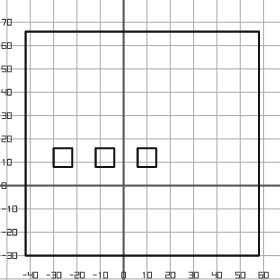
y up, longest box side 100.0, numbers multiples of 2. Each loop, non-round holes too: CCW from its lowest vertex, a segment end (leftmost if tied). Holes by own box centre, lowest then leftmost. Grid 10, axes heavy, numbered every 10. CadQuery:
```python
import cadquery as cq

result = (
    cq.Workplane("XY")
    .moveTo(-42.0, -30.0)
    .lineTo(58.0, -30.0)
    .lineTo(58.0, 66.0)
    .lineTo(-42.0, 66.0)
    .close()
    .moveTo(-30.0, 8.0)
    .lineTo(-22.0, 8.0)
    .lineTo(-22.0, 16.0)
    .lineTo(-30.0, 16.0)
    .close()
    .moveTo(-12.0, 8.0)
    .lineTo(-4.0, 8.0)
    .lineTo(-4.0, 16.0)
    .lineTo(-12.0, 16.0)
    .close()
    .moveTo(6.0, 8.0)
    .lineTo(14.0, 8.0)
    .lineTo(14.0, 16.0)
    .lineTo(6.0, 16.0)
    .close()
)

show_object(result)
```